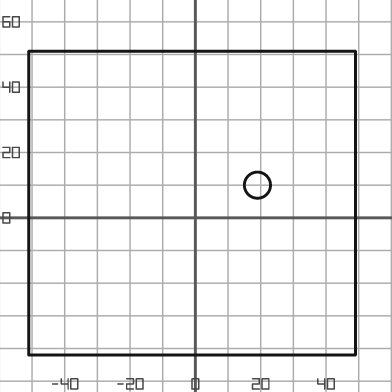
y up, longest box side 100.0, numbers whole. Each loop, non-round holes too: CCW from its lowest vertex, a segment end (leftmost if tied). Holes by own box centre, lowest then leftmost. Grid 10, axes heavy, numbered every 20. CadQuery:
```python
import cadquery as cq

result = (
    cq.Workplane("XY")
    .moveTo(-51.0, -42.0)
    .lineTo(49.0, -42.0)
    .lineTo(49.0, 51.0)
    .lineTo(-51.0, 51.0)
    .close()
    .moveTo(19.0, 10.0)
    .circle(4.0)
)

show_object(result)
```